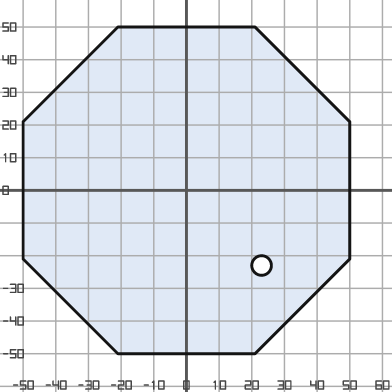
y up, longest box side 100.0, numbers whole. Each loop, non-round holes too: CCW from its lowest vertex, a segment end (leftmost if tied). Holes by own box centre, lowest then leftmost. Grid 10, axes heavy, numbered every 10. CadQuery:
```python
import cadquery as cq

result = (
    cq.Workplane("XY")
    .moveTo(-21.0, -50.0)
    .lineTo(21.0, -50.0)
    .lineTo(50.0, -21.0)
    .lineTo(50.0, 21.0)
    .lineTo(21.0, 50.0)
    .lineTo(-21.0, 50.0)
    .lineTo(-50.0, 21.0)
    .lineTo(-50.0, -21.0)
    .close()
    .moveTo(23.0, -23.0)
    .circle(3.0)
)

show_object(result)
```